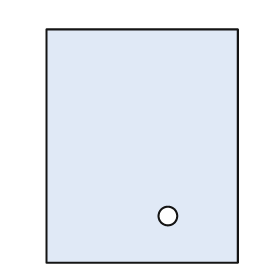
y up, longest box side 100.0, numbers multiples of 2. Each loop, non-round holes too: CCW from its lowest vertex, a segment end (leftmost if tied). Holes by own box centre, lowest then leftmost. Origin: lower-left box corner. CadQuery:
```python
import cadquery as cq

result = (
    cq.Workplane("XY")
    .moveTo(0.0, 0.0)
    .lineTo(82.0, 0.0)
    .lineTo(82.0, 100.0)
    .lineTo(0.0, 100.0)
    .close()
    .moveTo(52.0, 20.0)
    .circle(4.0)
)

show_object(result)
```